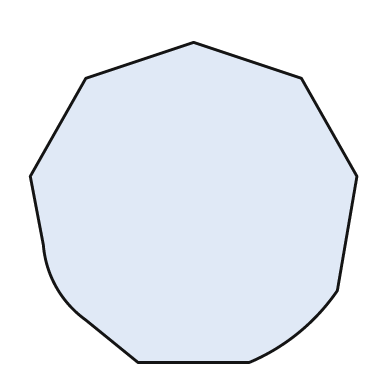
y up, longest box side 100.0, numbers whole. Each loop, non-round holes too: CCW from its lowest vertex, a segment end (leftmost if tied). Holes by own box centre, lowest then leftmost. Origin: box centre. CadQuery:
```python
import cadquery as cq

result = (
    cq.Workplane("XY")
    .moveTo(-17.0, -49.0)
    .lineTo(17.0, -49.0)
    .threePointArc((32.0, -40.0), (44.0, -27.0))
    .lineTo(50.0, 8.0)
    .lineTo(33.0, 38.0)
    .lineTo(0.0, 49.0)
    .lineTo(-33.0, 38.0)
    .lineTo(-50.0, 8.0)
    .lineTo(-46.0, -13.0)
    .threePointArc((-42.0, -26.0), (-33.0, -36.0))
    .close()
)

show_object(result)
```